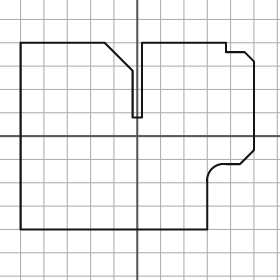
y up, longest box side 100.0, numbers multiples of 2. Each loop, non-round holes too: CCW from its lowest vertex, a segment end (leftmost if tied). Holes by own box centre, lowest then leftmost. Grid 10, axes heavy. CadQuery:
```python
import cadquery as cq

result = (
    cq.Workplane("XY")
    .moveTo(-50.0, -40.0)
    .lineTo(30.0, -40.0)
    .lineTo(30.0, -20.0)
    .threePointArc((32.0, -14.0), (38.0, -12.0))
    .lineTo(44.0, -12.0)
    .lineTo(50.0, -6.0)
    .lineTo(50.0, 32.0)
    .lineTo(46.0, 36.0)
    .lineTo(38.0, 36.0)
    .lineTo(38.0, 40.0)
    .lineTo(2.0, 40.0)
    .lineTo(2.0, 8.0)
    .lineTo(-2.0, 8.0)
    .lineTo(-2.0, 28.0)
    .lineTo(-14.0, 40.0)
    .lineTo(-50.0, 40.0)
    .close()
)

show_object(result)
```